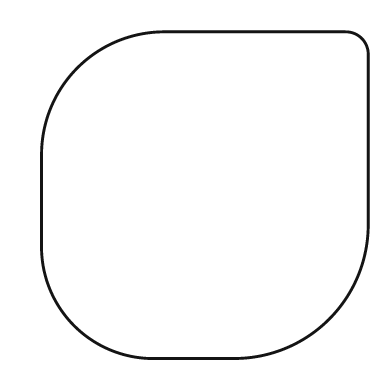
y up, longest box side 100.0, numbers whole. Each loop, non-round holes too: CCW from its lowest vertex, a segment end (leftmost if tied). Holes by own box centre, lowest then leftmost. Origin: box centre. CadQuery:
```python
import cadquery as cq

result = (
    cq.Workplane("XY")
    .moveTo(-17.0, -50.0)
    .lineTo(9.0, -50.0)
    .threePointArc((38.0, -38.0), (50.0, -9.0))
    .lineTo(50.0, 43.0)
    .threePointArc((48.0, 48.0), (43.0, 50.0))
    .lineTo(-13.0, 50.0)
    .threePointArc((-39.0, 39.0), (-50.0, 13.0))
    .lineTo(-50.0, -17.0)
    .threePointArc((-40.0, -40.0), (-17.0, -50.0))
    .close()
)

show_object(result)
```